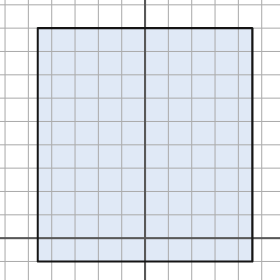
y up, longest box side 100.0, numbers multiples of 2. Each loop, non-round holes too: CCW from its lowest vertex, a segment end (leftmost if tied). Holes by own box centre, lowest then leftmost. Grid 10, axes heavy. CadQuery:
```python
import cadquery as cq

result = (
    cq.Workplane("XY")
    .moveTo(-46.0, -10.0)
    .lineTo(46.0, -10.0)
    .lineTo(46.0, 90.0)
    .lineTo(-46.0, 90.0)
    .close()
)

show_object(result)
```